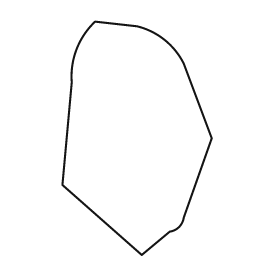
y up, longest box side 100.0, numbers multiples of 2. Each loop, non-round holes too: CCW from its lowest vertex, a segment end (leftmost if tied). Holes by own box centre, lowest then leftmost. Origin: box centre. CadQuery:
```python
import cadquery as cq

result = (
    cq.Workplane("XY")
    .moveTo(2.0, -50.0)
    .lineTo(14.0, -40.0)
    .threePointArc((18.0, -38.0), (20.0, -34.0))
    .lineTo(32.0, 0.0)
    .lineTo(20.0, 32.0)
    .threePointArc((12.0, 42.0), (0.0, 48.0))
    .lineTo(-18.0, 50.0)
    .threePointArc((-26.0, 38.0), (-28.0, 24.0))
    .lineTo(-32.0, -20.0)
    .close()
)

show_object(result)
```